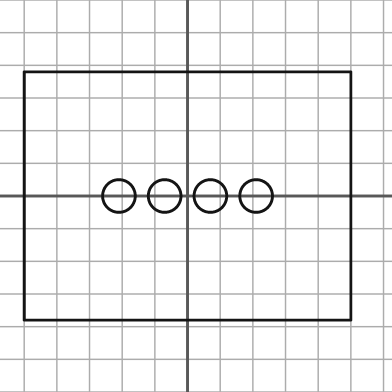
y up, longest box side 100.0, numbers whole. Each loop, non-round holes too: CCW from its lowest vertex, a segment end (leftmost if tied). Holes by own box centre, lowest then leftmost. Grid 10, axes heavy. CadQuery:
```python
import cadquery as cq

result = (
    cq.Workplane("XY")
    .moveTo(-50.0, -38.0)
    .lineTo(50.0, -38.0)
    .lineTo(50.0, 38.0)
    .lineTo(-50.0, 38.0)
    .close()
    .moveTo(-21.0, 0.0)
    .circle(5.0)
    .moveTo(-7.0, 0.0)
    .circle(5.0)
    .moveTo(7.0, 0.0)
    .circle(5.0)
    .moveTo(21.0, 0.0)
    .circle(5.0)
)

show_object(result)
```